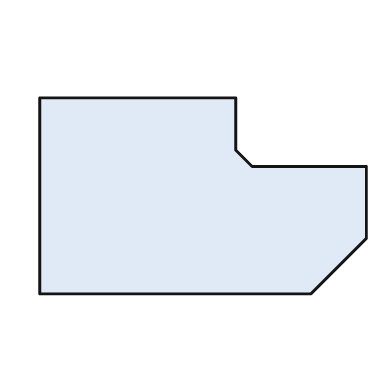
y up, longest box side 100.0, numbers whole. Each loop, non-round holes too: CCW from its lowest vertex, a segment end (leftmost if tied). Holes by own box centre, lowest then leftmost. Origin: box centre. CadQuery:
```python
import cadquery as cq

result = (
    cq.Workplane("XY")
    .moveTo(-50.0, -30.0)
    .lineTo(33.0, -30.0)
    .lineTo(50.0, -13.0)
    .lineTo(50.0, 9.0)
    .lineTo(15.0, 9.0)
    .lineTo(10.0, 14.0)
    .lineTo(10.0, 30.0)
    .lineTo(-50.0, 30.0)
    .close()
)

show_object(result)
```